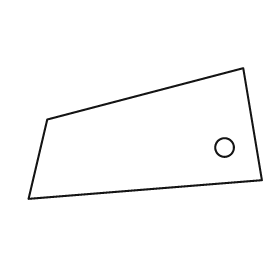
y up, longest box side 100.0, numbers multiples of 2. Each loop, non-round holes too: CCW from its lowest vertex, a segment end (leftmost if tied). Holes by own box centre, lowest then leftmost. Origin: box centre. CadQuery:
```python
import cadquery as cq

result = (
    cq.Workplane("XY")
    .moveTo(-50.0, -28.0)
    .lineTo(50.0, -20.0)
    .lineTo(42.0, 28.0)
    .lineTo(-42.0, 6.0)
    .close()
    .moveTo(34.0, -6.0)
    .circle(4.0)
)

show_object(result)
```